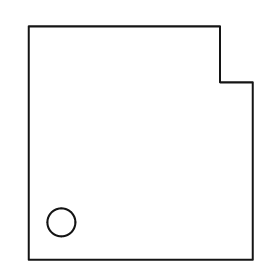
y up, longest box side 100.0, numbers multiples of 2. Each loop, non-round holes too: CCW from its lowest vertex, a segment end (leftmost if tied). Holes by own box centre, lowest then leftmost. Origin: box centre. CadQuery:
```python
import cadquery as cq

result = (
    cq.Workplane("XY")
    .moveTo(-48.0, -50.0)
    .lineTo(48.0, -50.0)
    .lineTo(48.0, 26.0)
    .lineTo(34.0, 26.0)
    .lineTo(34.0, 50.0)
    .lineTo(-48.0, 50.0)
    .close()
    .moveTo(-34.0, -34.0)
    .circle(6.0)
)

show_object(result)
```